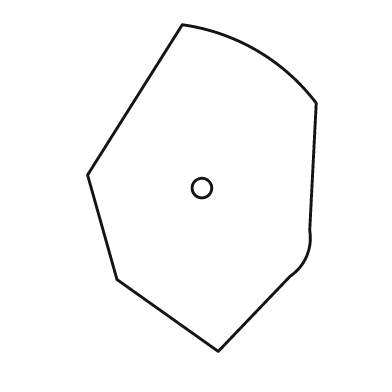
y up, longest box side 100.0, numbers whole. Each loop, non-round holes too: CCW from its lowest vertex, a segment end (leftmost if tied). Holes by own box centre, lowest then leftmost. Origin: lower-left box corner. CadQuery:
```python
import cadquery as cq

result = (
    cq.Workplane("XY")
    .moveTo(40.0, 0.0)
    .lineTo(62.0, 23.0)
    .threePointArc((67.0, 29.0), (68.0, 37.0))
    .lineTo(70.0, 76.0)
    .threePointArc((52.0, 92.0), (29.0, 100.0))
    .lineTo(0.0, 54.0)
    .lineTo(9.0, 22.0)
    .close()
    .moveTo(35.0, 50.0)
    .circle(3.0)
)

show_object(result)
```